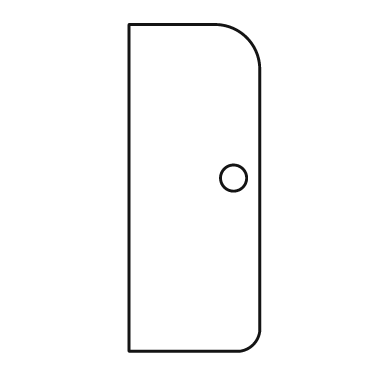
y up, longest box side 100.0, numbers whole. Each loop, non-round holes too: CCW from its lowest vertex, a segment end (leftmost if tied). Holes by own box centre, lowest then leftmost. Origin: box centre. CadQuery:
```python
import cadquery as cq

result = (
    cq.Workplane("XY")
    .moveTo(-20.0, -50.0)
    .lineTo(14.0, -50.0)
    .threePointArc((18.0, -48.0), (20.0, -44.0))
    .lineTo(20.0, 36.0)
    .threePointArc((16.0, 46.0), (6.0, 50.0))
    .lineTo(-20.0, 50.0)
    .close()
    .moveTo(12.0, 3.0)
    .circle(4.0)
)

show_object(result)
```